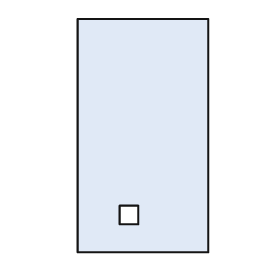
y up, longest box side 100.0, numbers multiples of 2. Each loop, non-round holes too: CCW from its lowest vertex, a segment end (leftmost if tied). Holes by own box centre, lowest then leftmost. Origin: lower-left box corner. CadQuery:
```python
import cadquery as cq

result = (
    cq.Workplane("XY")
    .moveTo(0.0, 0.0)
    .lineTo(56.0, 0.0)
    .lineTo(56.0, 100.0)
    .lineTo(0.0, 100.0)
    .close()
    .moveTo(18.0, 12.0)
    .lineTo(26.0, 12.0)
    .lineTo(26.0, 20.0)
    .lineTo(18.0, 20.0)
    .close()
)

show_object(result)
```